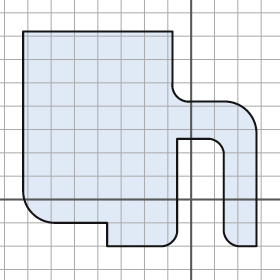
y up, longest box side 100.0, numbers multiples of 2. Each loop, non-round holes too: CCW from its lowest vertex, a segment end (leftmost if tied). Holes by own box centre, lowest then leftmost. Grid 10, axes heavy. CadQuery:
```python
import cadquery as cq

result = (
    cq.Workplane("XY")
    .moveTo(-36.0, -20.0)
    .lineTo(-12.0, -20.0)
    .threePointArc((-8.0, -18.0), (-6.0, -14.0))
    .lineTo(-6.0, 26.0)
    .lineTo(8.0, 26.0)
    .threePointArc((12.0, 24.0), (14.0, 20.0))
    .lineTo(14.0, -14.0)
    .threePointArc((16.0, -18.0), (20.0, -20.0))
    .lineTo(28.0, -20.0)
    .lineTo(28.0, 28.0)
    .threePointArc((24.0, 38.0), (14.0, 42.0))
    .lineTo(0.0, 42.0)
    .threePointArc((-6.0, 44.0), (-8.0, 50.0))
    .lineTo(-8.0, 72.0)
    .lineTo(-72.0, 72.0)
    .lineTo(-72.0, 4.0)
    .threePointArc((-68.0, -6.0), (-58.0, -10.0))
    .lineTo(-36.0, -10.0)
    .close()
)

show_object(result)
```